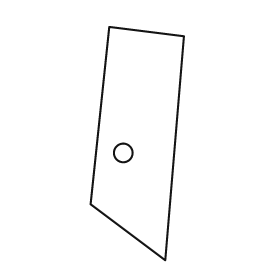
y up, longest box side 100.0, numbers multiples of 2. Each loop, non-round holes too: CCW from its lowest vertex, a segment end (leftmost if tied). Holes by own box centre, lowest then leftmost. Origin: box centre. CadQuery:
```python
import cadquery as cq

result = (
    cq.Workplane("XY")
    .moveTo(12.0, -50.0)
    .lineTo(20.0, 46.0)
    .lineTo(-12.0, 50.0)
    .lineTo(-20.0, -26.0)
    .close()
    .moveTo(-6.0, -4.0)
    .circle(4.0)
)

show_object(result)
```